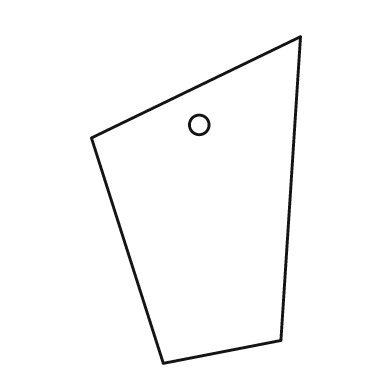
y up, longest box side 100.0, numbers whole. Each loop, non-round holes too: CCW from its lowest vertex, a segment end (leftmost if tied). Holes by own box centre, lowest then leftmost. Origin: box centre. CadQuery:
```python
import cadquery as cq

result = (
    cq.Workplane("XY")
    .moveTo(-10.0, -50.0)
    .lineTo(26.0, -43.0)
    .lineTo(32.0, 50.0)
    .lineTo(-32.0, 19.0)
    .close()
    .moveTo(1.0, 23.0)
    .circle(3.0)
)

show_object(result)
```